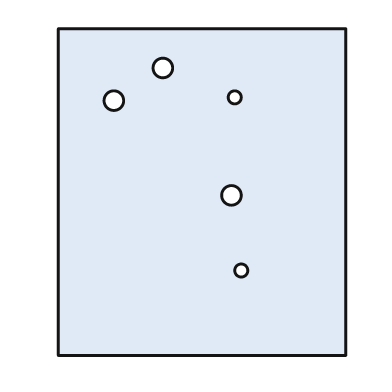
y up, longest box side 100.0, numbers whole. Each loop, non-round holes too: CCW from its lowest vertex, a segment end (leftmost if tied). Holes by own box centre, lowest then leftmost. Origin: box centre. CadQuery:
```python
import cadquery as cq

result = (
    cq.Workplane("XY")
    .moveTo(-44.0, -50.0)
    .lineTo(44.0, -50.0)
    .lineTo(44.0, 50.0)
    .lineTo(-44.0, 50.0)
    .close()
    .moveTo(12.0, -24.0)
    .circle(2.0)
    .moveTo(9.0, -1.0)
    .circle(3.0)
    .moveTo(-27.0, 28.0)
    .circle(3.0)
    .moveTo(10.0, 29.0)
    .circle(2.0)
    .moveTo(-12.0, 38.0)
    .circle(3.0)
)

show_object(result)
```